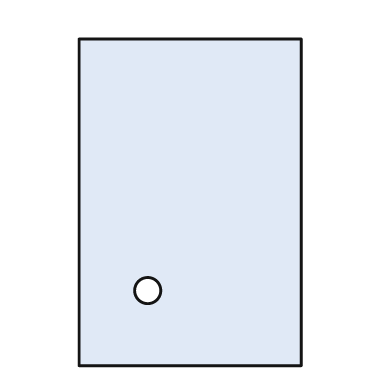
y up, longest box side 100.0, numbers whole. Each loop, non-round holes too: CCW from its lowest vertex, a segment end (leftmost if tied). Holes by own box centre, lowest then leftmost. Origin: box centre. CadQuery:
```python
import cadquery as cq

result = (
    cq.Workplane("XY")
    .moveTo(-34.0, -50.0)
    .lineTo(34.0, -50.0)
    .lineTo(34.0, 50.0)
    .lineTo(-34.0, 50.0)
    .close()
    .moveTo(-13.0, -27.0)
    .circle(4.0)
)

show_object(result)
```